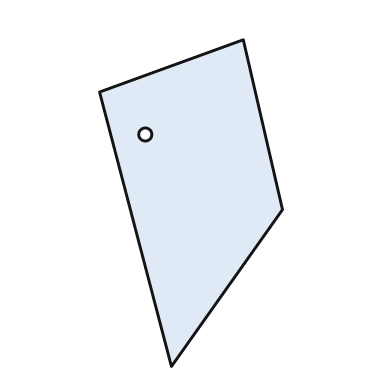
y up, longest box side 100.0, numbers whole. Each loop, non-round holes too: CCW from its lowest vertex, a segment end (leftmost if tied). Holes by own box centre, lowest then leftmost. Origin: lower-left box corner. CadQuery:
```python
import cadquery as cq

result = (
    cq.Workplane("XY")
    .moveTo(22.0, 0.0)
    .lineTo(56.0, 48.0)
    .lineTo(44.0, 100.0)
    .lineTo(0.0, 84.0)
    .close()
    .moveTo(14.0, 71.0)
    .circle(2.0)
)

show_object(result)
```